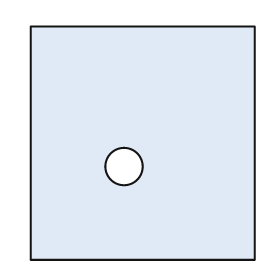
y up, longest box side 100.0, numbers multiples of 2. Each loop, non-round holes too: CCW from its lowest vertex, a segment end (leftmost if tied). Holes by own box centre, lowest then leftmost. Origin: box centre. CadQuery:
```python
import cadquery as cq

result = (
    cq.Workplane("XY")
    .moveTo(-48.0, -50.0)
    .lineTo(48.0, -50.0)
    .lineTo(48.0, 50.0)
    .lineTo(-48.0, 50.0)
    .close()
    .moveTo(-8.0, -10.0)
    .circle(8.0)
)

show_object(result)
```